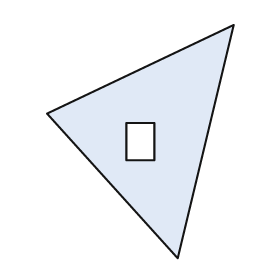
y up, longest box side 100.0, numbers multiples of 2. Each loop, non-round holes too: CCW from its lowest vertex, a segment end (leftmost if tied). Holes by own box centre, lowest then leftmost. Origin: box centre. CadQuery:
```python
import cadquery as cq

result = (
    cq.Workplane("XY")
    .moveTo(16.0, -50.0)
    .lineTo(40.0, 50.0)
    .lineTo(-40.0, 12.0)
    .close()
    .moveTo(-6.0, -8.0)
    .lineTo(6.0, -8.0)
    .lineTo(6.0, 8.0)
    .lineTo(-6.0, 8.0)
    .close()
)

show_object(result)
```